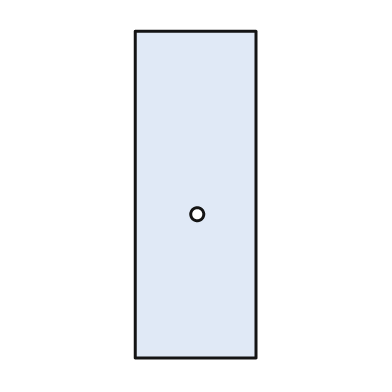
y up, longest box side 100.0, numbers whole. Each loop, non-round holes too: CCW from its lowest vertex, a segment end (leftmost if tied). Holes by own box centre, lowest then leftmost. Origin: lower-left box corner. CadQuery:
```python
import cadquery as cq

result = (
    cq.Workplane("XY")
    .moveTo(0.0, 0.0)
    .lineTo(37.0, 0.0)
    .lineTo(37.0, 100.0)
    .lineTo(0.0, 100.0)
    .close()
    .moveTo(19.0, 44.0)
    .circle(2.0)
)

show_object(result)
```